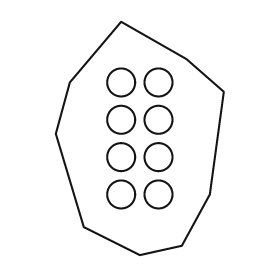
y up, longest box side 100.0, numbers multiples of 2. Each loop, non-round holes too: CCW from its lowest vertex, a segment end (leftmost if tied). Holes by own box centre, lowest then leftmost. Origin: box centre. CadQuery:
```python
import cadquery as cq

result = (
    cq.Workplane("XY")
    .moveTo(0.0, -50.0)
    .lineTo(18.0, -46.0)
    .lineTo(30.0, -24.0)
    .lineTo(36.0, 20.0)
    .lineTo(20.0, 34.0)
    .lineTo(-8.0, 50.0)
    .lineTo(-30.0, 24.0)
    .lineTo(-36.0, 2.0)
    .lineTo(-24.0, -38.0)
    .close()
    .moveTo(-8.0, -24.0)
    .circle(6.0)
    .moveTo(8.0, -24.0)
    .circle(6.0)
    .moveTo(-8.0, -8.0)
    .circle(6.0)
    .moveTo(8.0, -8.0)
    .circle(6.0)
    .moveTo(-8.0, 8.0)
    .circle(6.0)
    .moveTo(8.0, 8.0)
    .circle(6.0)
    .moveTo(-8.0, 24.0)
    .circle(6.0)
    .moveTo(8.0, 24.0)
    .circle(6.0)
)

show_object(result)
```